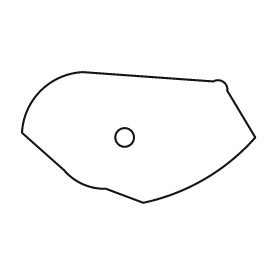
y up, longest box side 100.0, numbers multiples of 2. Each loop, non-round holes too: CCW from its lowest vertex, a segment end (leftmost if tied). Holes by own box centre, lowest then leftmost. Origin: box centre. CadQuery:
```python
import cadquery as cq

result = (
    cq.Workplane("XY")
    .moveTo(2.0, -28.0)
    .threePointArc((28.0, -18.0), (50.0, 0.0))
    .lineTo(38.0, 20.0)
    .threePointArc((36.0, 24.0), (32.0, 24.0))
    .lineTo(-24.0, 28.0)
    .threePointArc((-42.0, 20.0), (-50.0, 2.0))
    .lineTo(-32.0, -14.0)
    .threePointArc((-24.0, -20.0), (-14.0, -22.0))
    .close()
    .moveTo(-6.0, 0.0)
    .circle(4.0)
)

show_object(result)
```